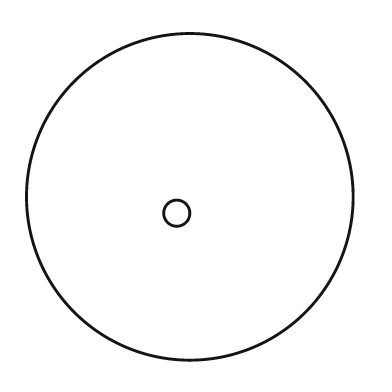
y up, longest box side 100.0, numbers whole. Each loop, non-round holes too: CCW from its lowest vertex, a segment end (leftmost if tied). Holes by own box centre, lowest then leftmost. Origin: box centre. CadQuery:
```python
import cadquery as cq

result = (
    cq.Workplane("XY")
    .moveTo(0.0, 0.0)
    .circle(50.0)
    .moveTo(-4.0, -5.0)
    .circle(4.0)
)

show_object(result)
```